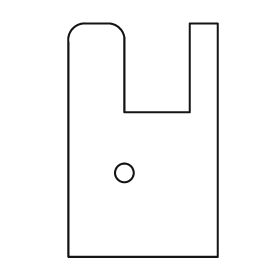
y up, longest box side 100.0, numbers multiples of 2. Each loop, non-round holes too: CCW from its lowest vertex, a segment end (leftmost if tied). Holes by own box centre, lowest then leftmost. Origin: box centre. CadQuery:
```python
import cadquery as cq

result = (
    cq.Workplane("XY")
    .moveTo(-32.0, -50.0)
    .lineTo(32.0, -50.0)
    .lineTo(32.0, 50.0)
    .lineTo(20.0, 50.0)
    .lineTo(20.0, 12.0)
    .lineTo(-8.0, 12.0)
    .lineTo(-8.0, 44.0)
    .threePointArc((-10.0, 48.0), (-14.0, 50.0))
    .lineTo(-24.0, 50.0)
    .threePointArc((-30.0, 48.0), (-32.0, 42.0))
    .close()
    .moveTo(-8.0, -14.0)
    .circle(4.0)
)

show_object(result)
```